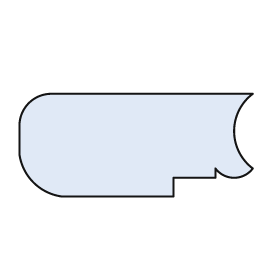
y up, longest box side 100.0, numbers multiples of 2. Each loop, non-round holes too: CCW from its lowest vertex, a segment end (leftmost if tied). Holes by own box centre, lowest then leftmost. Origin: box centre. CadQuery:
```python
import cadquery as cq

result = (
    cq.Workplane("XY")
    .moveTo(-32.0, -22.0)
    .lineTo(16.0, -22.0)
    .lineTo(16.0, -14.0)
    .lineTo(34.0, -14.0)
    .lineTo(34.0, -10.0)
    .threePointArc((42.0, -14.0), (50.0, -10.0))
    .threePointArc((42.0, 6.0), (50.0, 22.0))
    .lineTo(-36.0, 22.0)
    .threePointArc((-46.0, 18.0), (-50.0, 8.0))
    .lineTo(-50.0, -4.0)
    .threePointArc((-44.0, -16.0), (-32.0, -22.0))
    .close()
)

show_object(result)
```